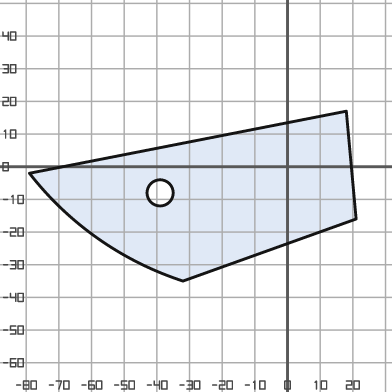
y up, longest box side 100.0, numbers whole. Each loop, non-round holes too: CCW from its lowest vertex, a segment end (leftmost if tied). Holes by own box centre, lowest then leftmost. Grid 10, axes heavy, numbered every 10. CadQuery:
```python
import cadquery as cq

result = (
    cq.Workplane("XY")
    .moveTo(-32.0, -35.0)
    .lineTo(21.0, -16.0)
    .lineTo(18.0, 17.0)
    .lineTo(-79.0, -2.0)
    .threePointArc((-58.0, -22.0), (-32.0, -35.0))
    .close()
    .moveTo(-39.0, -8.0)
    .circle(4.0)
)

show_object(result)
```